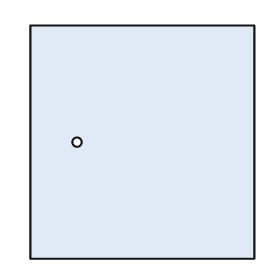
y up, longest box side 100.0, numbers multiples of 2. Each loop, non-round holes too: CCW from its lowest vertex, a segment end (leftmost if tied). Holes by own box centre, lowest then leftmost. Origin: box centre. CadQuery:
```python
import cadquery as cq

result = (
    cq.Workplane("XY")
    .moveTo(-48.0, -50.0)
    .lineTo(48.0, -50.0)
    .lineTo(48.0, 50.0)
    .lineTo(-48.0, 50.0)
    .close()
    .moveTo(-28.0, 0.0)
    .circle(2.0)
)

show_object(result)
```